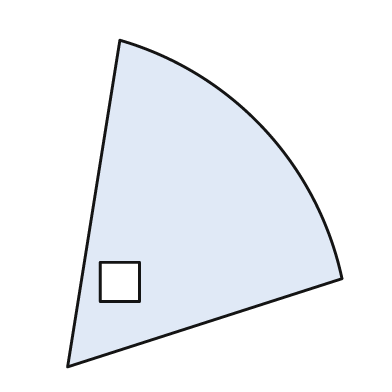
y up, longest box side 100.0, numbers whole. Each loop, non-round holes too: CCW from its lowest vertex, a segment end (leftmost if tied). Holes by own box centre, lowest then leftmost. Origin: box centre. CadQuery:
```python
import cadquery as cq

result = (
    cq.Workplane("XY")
    .moveTo(-42.0, -50.0)
    .lineTo(42.0, -23.0)
    .threePointArc((18.0, 23.0), (-26.0, 50.0))
    .close()
    .moveTo(-32.0, -30.0)
    .lineTo(-20.0, -30.0)
    .lineTo(-20.0, -18.0)
    .lineTo(-32.0, -18.0)
    .close()
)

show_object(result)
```